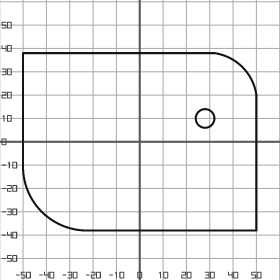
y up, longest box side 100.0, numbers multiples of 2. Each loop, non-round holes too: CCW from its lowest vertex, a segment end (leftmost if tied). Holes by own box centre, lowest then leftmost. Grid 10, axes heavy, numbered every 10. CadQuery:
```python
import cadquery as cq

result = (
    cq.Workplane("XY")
    .moveTo(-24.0, -38.0)
    .lineTo(50.0, -38.0)
    .lineTo(50.0, 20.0)
    .threePointArc((44.0, 32.0), (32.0, 38.0))
    .lineTo(-50.0, 38.0)
    .lineTo(-50.0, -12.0)
    .threePointArc((-42.0, -30.0), (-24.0, -38.0))
    .close()
    .moveTo(28.0, 10.0)
    .circle(4.0)
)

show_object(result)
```